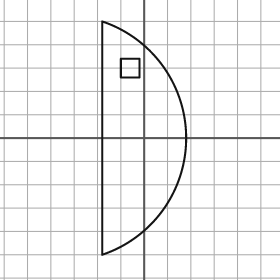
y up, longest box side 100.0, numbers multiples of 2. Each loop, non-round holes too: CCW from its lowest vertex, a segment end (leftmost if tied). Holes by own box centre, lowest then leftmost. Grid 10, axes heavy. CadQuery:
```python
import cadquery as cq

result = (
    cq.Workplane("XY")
    .moveTo(-18.0, -50.0)
    .threePointArc((18.0, 0.0), (-18.0, 50.0))
    .close()
    .moveTo(-10.0, 26.0)
    .lineTo(-2.0, 26.0)
    .lineTo(-2.0, 34.0)
    .lineTo(-10.0, 34.0)
    .close()
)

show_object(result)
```